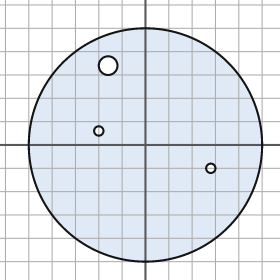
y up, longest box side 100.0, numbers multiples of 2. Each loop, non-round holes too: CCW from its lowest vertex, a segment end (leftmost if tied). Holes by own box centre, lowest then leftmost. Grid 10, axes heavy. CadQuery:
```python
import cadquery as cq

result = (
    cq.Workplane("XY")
    .moveTo(0.0, 0.0)
    .circle(50.0)
    .moveTo(28.0, -10.0)
    .circle(2.0)
    .moveTo(-20.0, 6.0)
    .circle(2.0)
    .moveTo(-16.0, 34.0)
    .circle(4.0)
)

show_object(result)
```